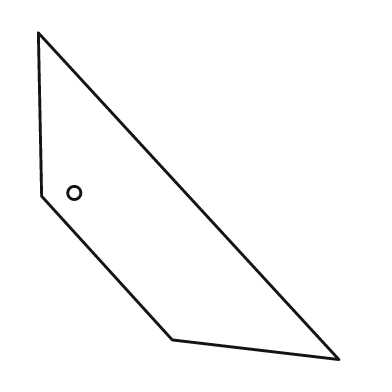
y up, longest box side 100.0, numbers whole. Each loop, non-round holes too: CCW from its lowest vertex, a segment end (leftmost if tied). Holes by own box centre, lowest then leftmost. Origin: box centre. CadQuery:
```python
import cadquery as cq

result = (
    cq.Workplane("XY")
    .moveTo(46.0, -50.0)
    .lineTo(-46.0, 50.0)
    .lineTo(-45.0, 0.0)
    .lineTo(-5.0, -44.0)
    .close()
    .moveTo(-35.0, 1.0)
    .circle(2.0)
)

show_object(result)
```